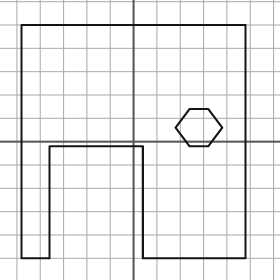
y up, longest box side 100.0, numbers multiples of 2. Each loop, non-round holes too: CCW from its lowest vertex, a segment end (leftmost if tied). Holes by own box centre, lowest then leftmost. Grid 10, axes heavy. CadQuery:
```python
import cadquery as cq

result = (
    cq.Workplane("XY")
    .moveTo(-48.0, -50.0)
    .lineTo(-36.0, -50.0)
    .lineTo(-36.0, -2.0)
    .lineTo(4.0, -2.0)
    .lineTo(4.0, -50.0)
    .lineTo(48.0, -50.0)
    .lineTo(48.0, 50.0)
    .lineTo(-48.0, 50.0)
    .close()
    .moveTo(24.0, -2.0)
    .lineTo(32.0, -2.0)
    .lineTo(38.0, 6.0)
    .lineTo(32.0, 14.0)
    .lineTo(24.0, 14.0)
    .lineTo(18.0, 6.0)
    .close()
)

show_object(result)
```